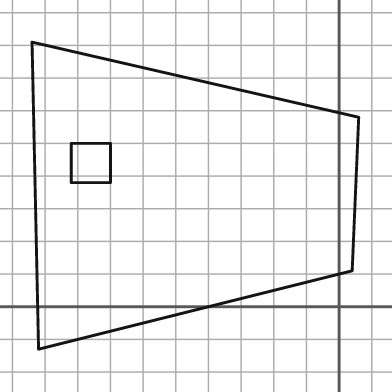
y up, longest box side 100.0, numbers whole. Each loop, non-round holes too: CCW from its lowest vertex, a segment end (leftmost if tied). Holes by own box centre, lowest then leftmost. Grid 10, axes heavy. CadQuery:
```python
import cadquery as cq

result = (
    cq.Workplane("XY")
    .moveTo(-92.0, -13.0)
    .lineTo(4.0, 11.0)
    .lineTo(6.0, 58.0)
    .lineTo(-94.0, 81.0)
    .close()
    .moveTo(-82.0, 38.0)
    .lineTo(-70.0, 38.0)
    .lineTo(-70.0, 50.0)
    .lineTo(-82.0, 50.0)
    .close()
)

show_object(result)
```